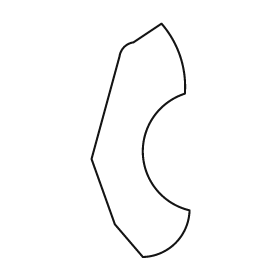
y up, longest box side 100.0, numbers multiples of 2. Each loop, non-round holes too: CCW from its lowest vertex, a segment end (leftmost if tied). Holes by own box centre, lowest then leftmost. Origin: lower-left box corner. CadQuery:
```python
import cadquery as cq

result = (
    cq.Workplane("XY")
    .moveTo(22.0, 0.0)
    .threePointArc((36.0, 6.0), (42.0, 20.0))
    .threePointArc((22.0, 44.0), (40.0, 70.0))
    .threePointArc((38.0, 86.0), (30.0, 100.0))
    .lineTo(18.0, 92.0)
    .threePointArc((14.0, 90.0), (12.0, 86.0))
    .lineTo(0.0, 42.0)
    .lineTo(10.0, 14.0)
    .close()
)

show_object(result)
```